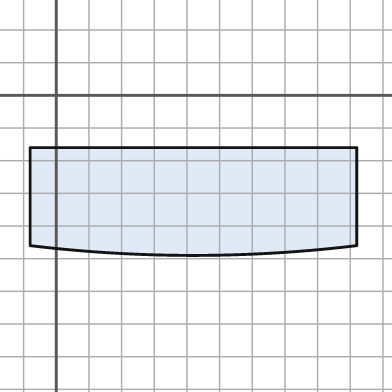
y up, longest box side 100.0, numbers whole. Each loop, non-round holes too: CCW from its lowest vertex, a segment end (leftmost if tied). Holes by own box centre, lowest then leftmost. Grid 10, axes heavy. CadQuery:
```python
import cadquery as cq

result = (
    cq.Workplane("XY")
    .moveTo(-8.0, -46.0)
    .threePointArc((42.0, -49.0), (92.0, -46.0))
    .lineTo(92.0, -16.0)
    .lineTo(-8.0, -16.0)
    .close()
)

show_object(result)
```